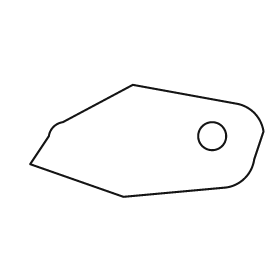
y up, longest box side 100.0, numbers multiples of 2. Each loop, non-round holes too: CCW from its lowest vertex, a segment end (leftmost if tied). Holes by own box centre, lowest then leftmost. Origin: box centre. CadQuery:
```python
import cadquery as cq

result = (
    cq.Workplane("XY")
    .moveTo(-10.0, -24.0)
    .lineTo(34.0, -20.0)
    .threePointArc((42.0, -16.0), (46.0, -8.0))
    .lineTo(50.0, 4.0)
    .threePointArc((46.0, 12.0), (38.0, 16.0))
    .lineTo(-6.0, 24.0)
    .lineTo(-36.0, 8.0)
    .threePointArc((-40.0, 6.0), (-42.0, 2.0))
    .lineTo(-50.0, -10.0)
    .close()
    .moveTo(28.0, 2.0)
    .circle(6.0)
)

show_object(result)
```